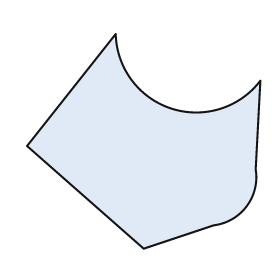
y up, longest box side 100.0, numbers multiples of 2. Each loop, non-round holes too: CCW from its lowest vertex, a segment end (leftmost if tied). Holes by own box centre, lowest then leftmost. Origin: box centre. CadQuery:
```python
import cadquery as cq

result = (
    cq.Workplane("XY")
    .moveTo(0.0, -46.0)
    .lineTo(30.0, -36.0)
    .threePointArc((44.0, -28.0), (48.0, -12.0))
    .lineTo(50.0, 26.0)
    .threePointArc((12.0, 14.0), (-12.0, 46.0))
    .lineTo(-50.0, -2.0)
    .close()
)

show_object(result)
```